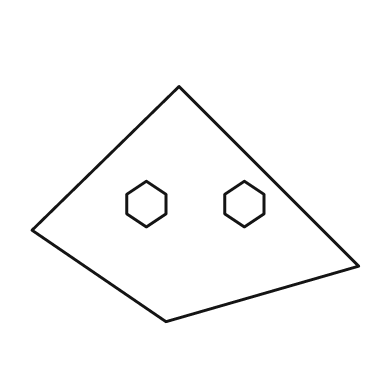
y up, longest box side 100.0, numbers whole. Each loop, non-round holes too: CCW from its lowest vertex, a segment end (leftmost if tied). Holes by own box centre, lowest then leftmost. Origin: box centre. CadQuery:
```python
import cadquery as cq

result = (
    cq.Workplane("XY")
    .moveTo(-9.0, -36.0)
    .lineTo(50.0, -19.0)
    .lineTo(-5.0, 36.0)
    .lineTo(-50.0, -8.0)
    .close()
    .moveTo(-15.0, -7.0)
    .lineTo(-9.0, -3.0)
    .lineTo(-9.0, 3.0)
    .lineTo(-15.0, 7.0)
    .lineTo(-21.0, 3.0)
    .lineTo(-21.0, -3.0)
    .close()
    .moveTo(15.0, -7.0)
    .lineTo(21.0, -3.0)
    .lineTo(21.0, 3.0)
    .lineTo(15.0, 7.0)
    .lineTo(9.0, 3.0)
    .lineTo(9.0, -3.0)
    .close()
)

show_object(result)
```